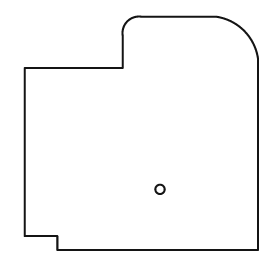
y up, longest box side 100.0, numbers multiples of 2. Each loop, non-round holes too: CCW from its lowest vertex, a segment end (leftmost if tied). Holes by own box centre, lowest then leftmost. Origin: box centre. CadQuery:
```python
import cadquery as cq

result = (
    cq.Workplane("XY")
    .moveTo(-36.0, -50.0)
    .lineTo(50.0, -50.0)
    .lineTo(50.0, 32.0)
    .threePointArc((44.0, 44.0), (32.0, 50.0))
    .lineTo(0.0, 50.0)
    .threePointArc((-6.0, 48.0), (-8.0, 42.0))
    .lineTo(-8.0, 28.0)
    .lineTo(-50.0, 28.0)
    .lineTo(-50.0, -44.0)
    .lineTo(-36.0, -44.0)
    .close()
    .moveTo(8.0, -24.0)
    .circle(2.0)
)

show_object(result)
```